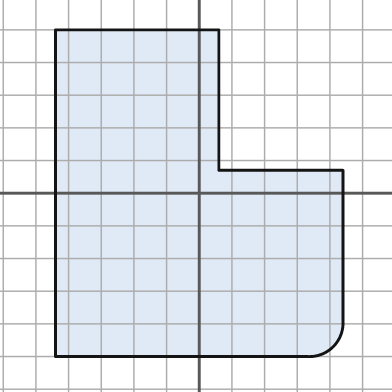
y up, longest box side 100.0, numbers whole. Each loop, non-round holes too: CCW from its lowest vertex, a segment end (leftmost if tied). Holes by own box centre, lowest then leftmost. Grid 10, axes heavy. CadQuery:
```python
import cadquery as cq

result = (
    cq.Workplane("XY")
    .moveTo(-44.0, -50.0)
    .lineTo(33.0, -50.0)
    .threePointArc((41.0, -47.0), (44.0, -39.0))
    .lineTo(44.0, 7.0)
    .lineTo(6.0, 7.0)
    .lineTo(6.0, 50.0)
    .lineTo(-44.0, 50.0)
    .close()
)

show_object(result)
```